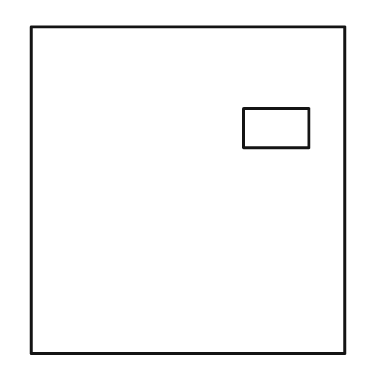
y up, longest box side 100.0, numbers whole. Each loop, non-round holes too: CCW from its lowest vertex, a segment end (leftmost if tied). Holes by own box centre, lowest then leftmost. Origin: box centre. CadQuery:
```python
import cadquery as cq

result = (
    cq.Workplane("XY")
    .moveTo(-48.0, -50.0)
    .lineTo(48.0, -50.0)
    .lineTo(48.0, 50.0)
    .lineTo(-48.0, 50.0)
    .close()
    .moveTo(17.0, 13.0)
    .lineTo(37.0, 13.0)
    .lineTo(37.0, 25.0)
    .lineTo(17.0, 25.0)
    .close()
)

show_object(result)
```